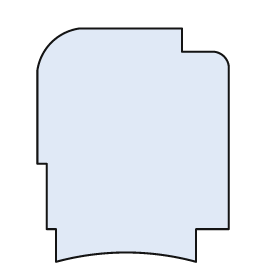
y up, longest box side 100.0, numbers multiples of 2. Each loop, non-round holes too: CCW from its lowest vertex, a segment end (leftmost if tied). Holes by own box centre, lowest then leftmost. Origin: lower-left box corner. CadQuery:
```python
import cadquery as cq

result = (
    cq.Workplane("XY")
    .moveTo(8.0, 0.0)
    .threePointArc((38.0, 4.0), (68.0, 0.0))
    .lineTo(68.0, 14.0)
    .lineTo(82.0, 14.0)
    .lineTo(82.0, 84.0)
    .threePointArc((80.0, 88.0), (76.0, 90.0))
    .lineTo(62.0, 90.0)
    .lineTo(62.0, 100.0)
    .lineTo(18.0, 100.0)
    .threePointArc((6.0, 94.0), (0.0, 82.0))
    .lineTo(0.0, 42.0)
    .lineTo(4.0, 42.0)
    .lineTo(4.0, 14.0)
    .lineTo(8.0, 14.0)
    .close()
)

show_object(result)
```